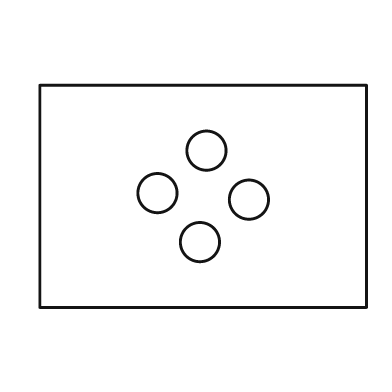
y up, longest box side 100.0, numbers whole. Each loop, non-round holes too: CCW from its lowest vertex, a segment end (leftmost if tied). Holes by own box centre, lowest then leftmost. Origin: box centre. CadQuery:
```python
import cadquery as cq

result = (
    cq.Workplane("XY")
    .moveTo(-50.0, -34.0)
    .lineTo(50.0, -34.0)
    .lineTo(50.0, 34.0)
    .lineTo(-50.0, 34.0)
    .close()
    .moveTo(-1.0, -14.0)
    .circle(6.0)
    .moveTo(14.0, -1.0)
    .circle(6.0)
    .moveTo(-14.0, 1.0)
    .circle(6.0)
    .moveTo(1.0, 14.0)
    .circle(6.0)
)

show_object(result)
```